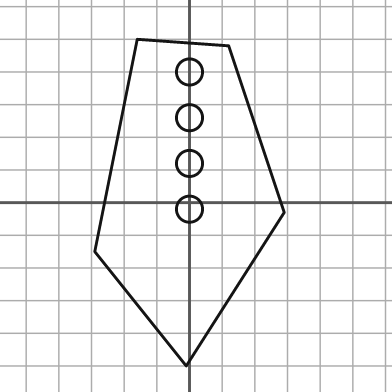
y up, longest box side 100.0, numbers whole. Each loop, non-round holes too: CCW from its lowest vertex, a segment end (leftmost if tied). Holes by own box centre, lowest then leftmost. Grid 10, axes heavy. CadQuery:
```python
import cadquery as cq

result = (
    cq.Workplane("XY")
    .moveTo(-1.0, -50.0)
    .lineTo(29.0, -3.0)
    .lineTo(12.0, 48.0)
    .lineTo(-16.0, 50.0)
    .lineTo(-29.0, -15.0)
    .close()
    .moveTo(0.0, -2.0)
    .circle(4.0)
    .moveTo(0.0, 12.0)
    .circle(4.0)
    .moveTo(0.0, 26.0)
    .circle(4.0)
    .moveTo(0.0, 40.0)
    .circle(4.0)
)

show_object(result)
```